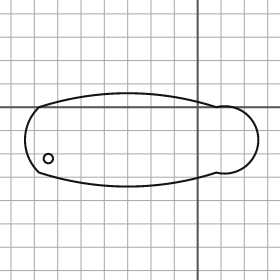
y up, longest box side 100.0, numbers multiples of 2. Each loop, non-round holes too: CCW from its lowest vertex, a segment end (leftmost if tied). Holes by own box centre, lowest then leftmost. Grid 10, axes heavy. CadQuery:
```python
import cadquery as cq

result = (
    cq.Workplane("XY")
    .moveTo(-68.0, -28.0)
    .threePointArc((-30.0, -34.0), (8.0, -28.0))
    .threePointArc((26.0, -14.0), (8.0, 0.0))
    .threePointArc((-30.0, 6.0), (-68.0, 0.0))
    .threePointArc((-74.0, -14.0), (-68.0, -28.0))
    .close()
    .moveTo(-64.0, -22.0)
    .circle(2.0)
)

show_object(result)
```